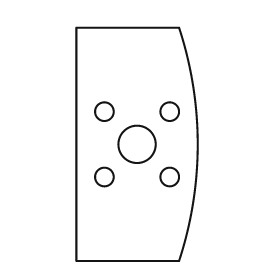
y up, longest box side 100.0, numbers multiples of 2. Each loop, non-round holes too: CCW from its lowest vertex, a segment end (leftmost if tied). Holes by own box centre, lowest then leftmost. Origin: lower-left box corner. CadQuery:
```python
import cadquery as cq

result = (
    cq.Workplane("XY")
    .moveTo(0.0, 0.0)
    .lineTo(44.0, 0.0)
    .threePointArc((52.0, 50.0), (44.0, 100.0))
    .lineTo(0.0, 100.0)
    .close()
    .moveTo(12.0, 36.0)
    .circle(4.0)
    .moveTo(40.0, 36.0)
    .circle(4.0)
    .moveTo(26.0, 50.0)
    .circle(8.0)
    .moveTo(12.0, 64.0)
    .circle(4.0)
    .moveTo(40.0, 64.0)
    .circle(4.0)
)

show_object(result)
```